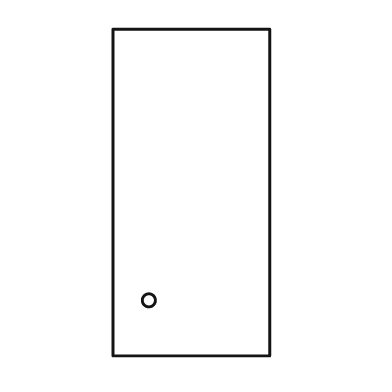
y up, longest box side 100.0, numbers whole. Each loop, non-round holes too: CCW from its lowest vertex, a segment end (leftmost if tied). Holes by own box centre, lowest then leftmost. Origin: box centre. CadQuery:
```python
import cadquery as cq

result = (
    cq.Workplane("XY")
    .moveTo(-24.0, -50.0)
    .lineTo(24.0, -50.0)
    .lineTo(24.0, 50.0)
    .lineTo(-24.0, 50.0)
    .close()
    .moveTo(-13.0, -33.0)
    .circle(2.0)
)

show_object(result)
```